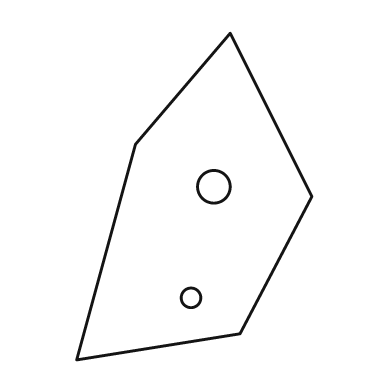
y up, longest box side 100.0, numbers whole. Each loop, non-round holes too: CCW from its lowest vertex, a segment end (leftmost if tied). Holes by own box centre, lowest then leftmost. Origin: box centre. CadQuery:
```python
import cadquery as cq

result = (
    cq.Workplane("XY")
    .moveTo(-36.0, -50.0)
    .lineTo(14.0, -42.0)
    .lineTo(36.0, 0.0)
    .lineTo(11.0, 50.0)
    .lineTo(-18.0, 16.0)
    .close()
    .moveTo(-1.0, -31.0)
    .circle(3.0)
    .moveTo(6.0, 3.0)
    .circle(5.0)
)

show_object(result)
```